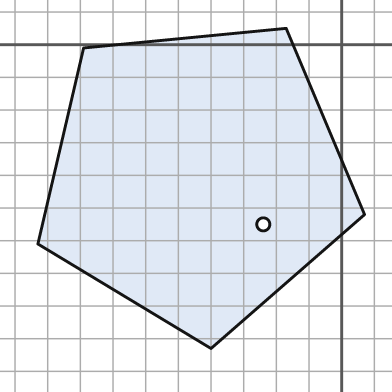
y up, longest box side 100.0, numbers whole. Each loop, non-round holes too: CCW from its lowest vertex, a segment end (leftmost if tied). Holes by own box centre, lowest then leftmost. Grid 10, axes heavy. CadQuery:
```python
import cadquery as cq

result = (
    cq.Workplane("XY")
    .moveTo(-40.0, -93.0)
    .lineTo(7.0, -52.0)
    .lineTo(-17.0, 5.0)
    .lineTo(-79.0, -1.0)
    .lineTo(-93.0, -61.0)
    .close()
    .moveTo(-24.0, -55.0)
    .circle(2.0)
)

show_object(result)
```